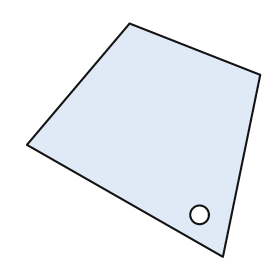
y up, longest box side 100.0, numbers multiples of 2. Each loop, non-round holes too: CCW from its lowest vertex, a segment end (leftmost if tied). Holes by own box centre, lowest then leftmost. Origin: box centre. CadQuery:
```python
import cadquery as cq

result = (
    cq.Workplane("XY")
    .moveTo(34.0, -50.0)
    .lineTo(50.0, 28.0)
    .lineTo(-6.0, 50.0)
    .lineTo(-50.0, -2.0)
    .close()
    .moveTo(24.0, -32.0)
    .circle(4.0)
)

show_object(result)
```